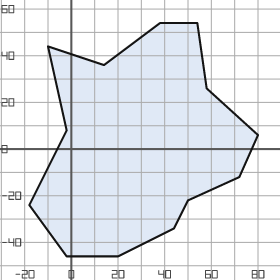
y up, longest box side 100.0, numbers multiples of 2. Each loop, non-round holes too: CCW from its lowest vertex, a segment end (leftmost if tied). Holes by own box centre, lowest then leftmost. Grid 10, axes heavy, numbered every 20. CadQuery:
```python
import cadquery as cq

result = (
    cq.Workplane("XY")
    .moveTo(-2.0, -46.0)
    .lineTo(20.0, -46.0)
    .lineTo(44.0, -34.0)
    .lineTo(50.0, -22.0)
    .lineTo(72.0, -12.0)
    .lineTo(80.0, 6.0)
    .lineTo(58.0, 26.0)
    .lineTo(54.0, 54.0)
    .lineTo(38.0, 54.0)
    .lineTo(14.0, 36.0)
    .lineTo(-10.0, 44.0)
    .lineTo(-2.0, 8.0)
    .lineTo(-18.0, -24.0)
    .close()
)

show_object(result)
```